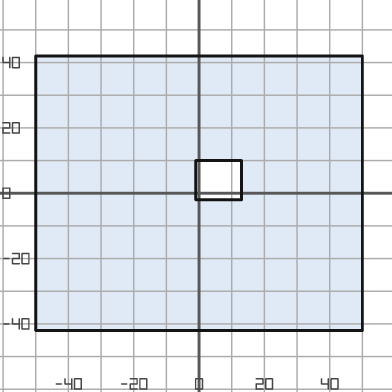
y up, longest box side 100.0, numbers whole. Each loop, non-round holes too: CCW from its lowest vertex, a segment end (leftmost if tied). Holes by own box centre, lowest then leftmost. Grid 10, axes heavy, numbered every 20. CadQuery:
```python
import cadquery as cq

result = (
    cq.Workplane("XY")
    .moveTo(-50.0, -42.0)
    .lineTo(50.0, -42.0)
    .lineTo(50.0, 42.0)
    .lineTo(-50.0, 42.0)
    .close()
    .moveTo(-1.0, -2.0)
    .lineTo(13.0, -2.0)
    .lineTo(13.0, 10.0)
    .lineTo(-1.0, 10.0)
    .close()
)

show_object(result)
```